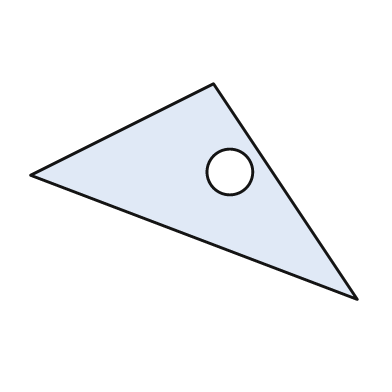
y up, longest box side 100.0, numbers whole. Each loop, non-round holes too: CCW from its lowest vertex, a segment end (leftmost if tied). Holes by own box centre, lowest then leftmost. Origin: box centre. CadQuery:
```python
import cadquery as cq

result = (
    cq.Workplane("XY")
    .moveTo(50.0, -33.0)
    .lineTo(6.0, 33.0)
    .lineTo(-50.0, 5.0)
    .close()
    .moveTo(11.0, 6.0)
    .circle(7.0)
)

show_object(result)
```